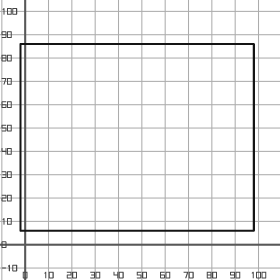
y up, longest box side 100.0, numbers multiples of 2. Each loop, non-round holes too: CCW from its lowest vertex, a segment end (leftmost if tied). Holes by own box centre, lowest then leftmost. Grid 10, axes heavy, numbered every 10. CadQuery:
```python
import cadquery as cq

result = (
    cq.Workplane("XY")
    .moveTo(-2.0, 6.0)
    .lineTo(98.0, 6.0)
    .lineTo(98.0, 86.0)
    .lineTo(-2.0, 86.0)
    .close()
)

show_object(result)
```